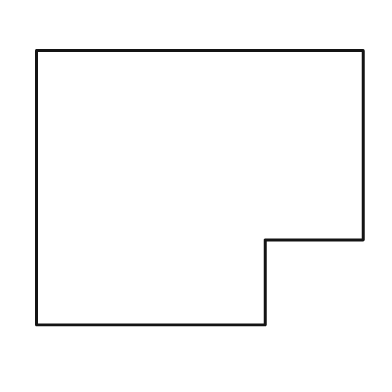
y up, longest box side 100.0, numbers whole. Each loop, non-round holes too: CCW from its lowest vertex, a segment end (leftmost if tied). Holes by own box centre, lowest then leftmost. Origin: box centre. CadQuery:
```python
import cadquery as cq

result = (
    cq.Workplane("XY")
    .moveTo(-50.0, -42.0)
    .lineTo(20.0, -42.0)
    .lineTo(20.0, -16.0)
    .lineTo(50.0, -16.0)
    .lineTo(50.0, 42.0)
    .lineTo(-50.0, 42.0)
    .close()
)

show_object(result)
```